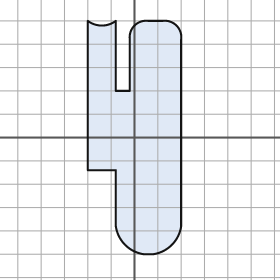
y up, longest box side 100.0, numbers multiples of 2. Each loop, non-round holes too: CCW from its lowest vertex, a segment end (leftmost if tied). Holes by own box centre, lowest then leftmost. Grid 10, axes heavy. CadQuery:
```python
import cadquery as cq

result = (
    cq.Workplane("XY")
    .moveTo(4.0, -50.0)
    .lineTo(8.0, -50.0)
    .threePointArc((16.0, -46.0), (20.0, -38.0))
    .lineTo(20.0, 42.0)
    .threePointArc((18.0, 48.0), (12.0, 50.0))
    .lineTo(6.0, 50.0)
    .threePointArc((0.0, 48.0), (-2.0, 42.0))
    .lineTo(-2.0, 20.0)
    .lineTo(-8.0, 20.0)
    .lineTo(-8.0, 50.0)
    .threePointArc((-14.0, 48.0), (-20.0, 50.0))
    .lineTo(-20.0, -14.0)
    .lineTo(-8.0, -14.0)
    .lineTo(-8.0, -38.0)
    .threePointArc((-4.0, -46.0), (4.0, -50.0))
    .close()
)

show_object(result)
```